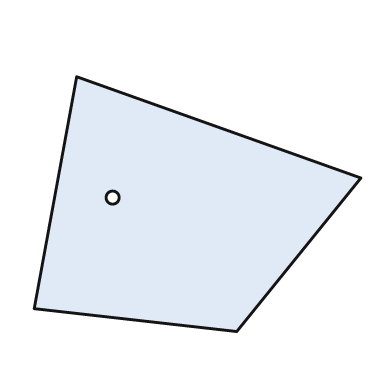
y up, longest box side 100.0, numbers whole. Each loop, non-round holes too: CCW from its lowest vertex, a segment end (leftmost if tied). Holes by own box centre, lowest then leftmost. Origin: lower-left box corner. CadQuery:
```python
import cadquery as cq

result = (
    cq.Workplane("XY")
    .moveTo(62.0, 0.0)
    .lineTo(100.0, 47.0)
    .lineTo(13.0, 78.0)
    .lineTo(0.0, 7.0)
    .close()
    .moveTo(24.0, 41.0)
    .circle(2.0)
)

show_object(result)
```